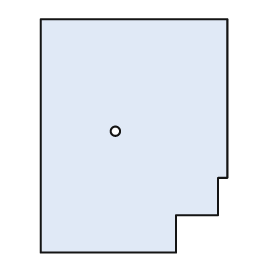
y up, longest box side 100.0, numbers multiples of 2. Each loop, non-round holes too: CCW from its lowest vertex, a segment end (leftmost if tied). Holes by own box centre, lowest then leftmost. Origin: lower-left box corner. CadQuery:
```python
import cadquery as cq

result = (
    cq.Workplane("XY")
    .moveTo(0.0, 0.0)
    .lineTo(58.0, 0.0)
    .lineTo(58.0, 16.0)
    .lineTo(76.0, 16.0)
    .lineTo(76.0, 32.0)
    .lineTo(80.0, 32.0)
    .lineTo(80.0, 100.0)
    .lineTo(0.0, 100.0)
    .close()
    .moveTo(32.0, 52.0)
    .circle(2.0)
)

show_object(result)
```